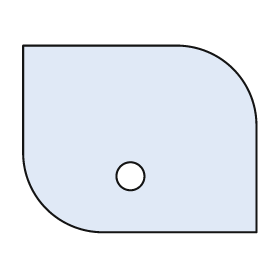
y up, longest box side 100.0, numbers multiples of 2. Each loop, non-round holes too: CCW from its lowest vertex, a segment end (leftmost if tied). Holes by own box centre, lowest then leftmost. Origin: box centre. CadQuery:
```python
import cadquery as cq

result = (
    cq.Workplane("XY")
    .moveTo(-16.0, -40.0)
    .lineTo(50.0, -40.0)
    .lineTo(50.0, 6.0)
    .threePointArc((40.0, 30.0), (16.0, 40.0))
    .lineTo(-50.0, 40.0)
    .lineTo(-50.0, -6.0)
    .threePointArc((-40.0, -30.0), (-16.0, -40.0))
    .close()
    .moveTo(-4.0, -16.0)
    .circle(6.0)
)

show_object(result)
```